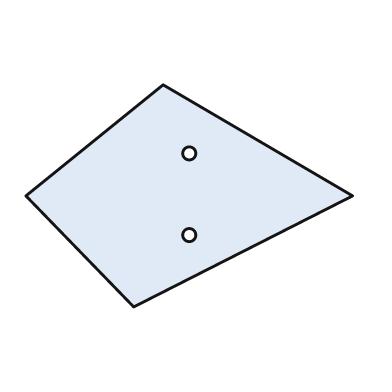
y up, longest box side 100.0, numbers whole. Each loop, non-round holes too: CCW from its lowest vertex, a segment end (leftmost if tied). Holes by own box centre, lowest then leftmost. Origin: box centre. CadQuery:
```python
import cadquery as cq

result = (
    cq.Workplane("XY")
    .moveTo(-17.0, -34.0)
    .lineTo(50.0, 0.0)
    .lineTo(-8.0, 34.0)
    .lineTo(-50.0, 0.0)
    .close()
    .moveTo(0.0, -12.0)
    .circle(2.0)
    .moveTo(0.0, 13.0)
    .circle(2.0)
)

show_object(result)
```